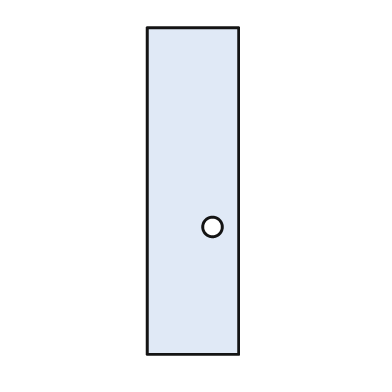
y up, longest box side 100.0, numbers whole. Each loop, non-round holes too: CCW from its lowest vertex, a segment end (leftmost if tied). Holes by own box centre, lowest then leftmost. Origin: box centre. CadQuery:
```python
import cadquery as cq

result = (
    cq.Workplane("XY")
    .moveTo(-14.0, -50.0)
    .lineTo(14.0, -50.0)
    .lineTo(14.0, 50.0)
    .lineTo(-14.0, 50.0)
    .close()
    .moveTo(6.0, -11.0)
    .circle(3.0)
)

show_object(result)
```